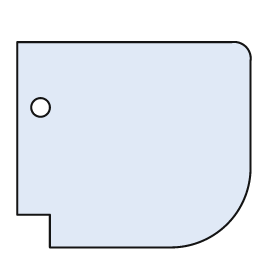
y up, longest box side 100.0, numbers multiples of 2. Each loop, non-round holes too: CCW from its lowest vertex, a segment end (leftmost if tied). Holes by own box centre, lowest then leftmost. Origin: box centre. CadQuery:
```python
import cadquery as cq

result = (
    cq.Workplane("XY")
    .moveTo(-36.0, -44.0)
    .lineTo(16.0, -44.0)
    .threePointArc((40.0, -34.0), (50.0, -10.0))
    .lineTo(50.0, 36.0)
    .threePointArc((48.0, 42.0), (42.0, 44.0))
    .lineTo(-50.0, 44.0)
    .lineTo(-50.0, -30.0)
    .lineTo(-36.0, -30.0)
    .close()
    .moveTo(-40.0, 16.0)
    .circle(4.0)
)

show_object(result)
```